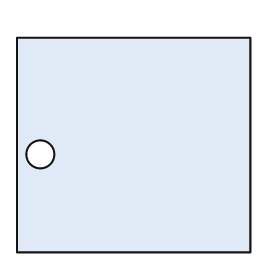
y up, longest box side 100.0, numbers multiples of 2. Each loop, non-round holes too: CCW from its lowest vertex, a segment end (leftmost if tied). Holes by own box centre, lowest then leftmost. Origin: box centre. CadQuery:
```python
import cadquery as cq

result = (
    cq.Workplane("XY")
    .moveTo(-50.0, -46.0)
    .lineTo(50.0, -46.0)
    .lineTo(50.0, 46.0)
    .lineTo(-50.0, 46.0)
    .close()
    .moveTo(-40.0, -4.0)
    .circle(6.0)
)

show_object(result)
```